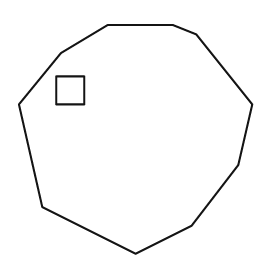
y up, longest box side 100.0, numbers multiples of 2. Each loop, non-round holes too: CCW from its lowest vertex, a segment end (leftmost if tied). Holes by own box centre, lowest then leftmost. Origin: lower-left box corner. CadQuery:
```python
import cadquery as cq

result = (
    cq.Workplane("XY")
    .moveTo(50.0, 0.0)
    .lineTo(74.0, 12.0)
    .lineTo(94.0, 38.0)
    .lineTo(100.0, 64.0)
    .lineTo(76.0, 94.0)
    .lineTo(66.0, 98.0)
    .lineTo(38.0, 98.0)
    .lineTo(18.0, 86.0)
    .lineTo(0.0, 64.0)
    .lineTo(10.0, 20.0)
    .close()
    .moveTo(16.0, 64.0)
    .lineTo(28.0, 64.0)
    .lineTo(28.0, 76.0)
    .lineTo(16.0, 76.0)
    .close()
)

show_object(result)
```